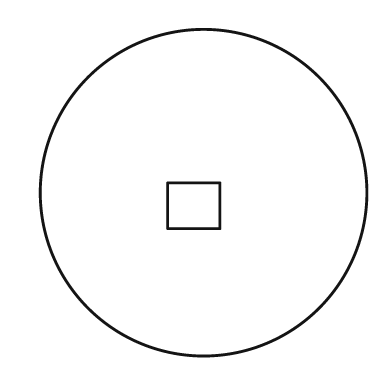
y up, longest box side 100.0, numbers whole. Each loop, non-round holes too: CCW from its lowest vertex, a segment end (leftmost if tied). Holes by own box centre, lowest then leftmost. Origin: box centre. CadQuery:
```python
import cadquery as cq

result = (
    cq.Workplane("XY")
    .moveTo(0.0, 0.0)
    .circle(50.0)
    .moveTo(-11.0, -11.0)
    .lineTo(5.0, -11.0)
    .lineTo(5.0, 3.0)
    .lineTo(-11.0, 3.0)
    .close()
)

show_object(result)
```